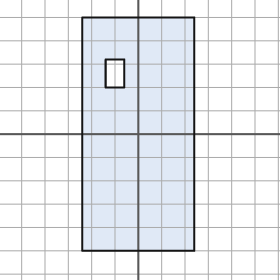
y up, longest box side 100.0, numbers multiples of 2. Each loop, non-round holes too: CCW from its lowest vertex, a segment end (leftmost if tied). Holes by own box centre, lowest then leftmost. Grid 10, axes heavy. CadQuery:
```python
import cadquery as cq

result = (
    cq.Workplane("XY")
    .moveTo(-24.0, -50.0)
    .lineTo(24.0, -50.0)
    .lineTo(24.0, 50.0)
    .lineTo(-24.0, 50.0)
    .close()
    .moveTo(-14.0, 20.0)
    .lineTo(-6.0, 20.0)
    .lineTo(-6.0, 32.0)
    .lineTo(-14.0, 32.0)
    .close()
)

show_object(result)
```